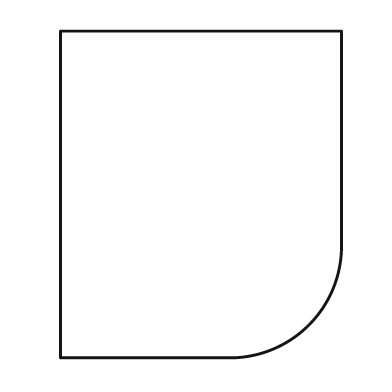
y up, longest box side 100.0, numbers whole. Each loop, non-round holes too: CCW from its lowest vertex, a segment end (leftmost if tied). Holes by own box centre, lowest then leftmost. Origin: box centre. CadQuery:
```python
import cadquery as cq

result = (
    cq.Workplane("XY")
    .moveTo(-43.0, -50.0)
    .lineTo(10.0, -50.0)
    .threePointArc((33.0, -40.0), (43.0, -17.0))
    .lineTo(43.0, 50.0)
    .lineTo(-43.0, 50.0)
    .close()
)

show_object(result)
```